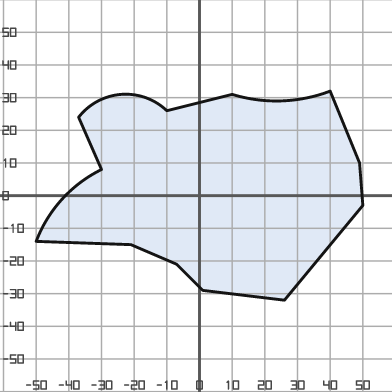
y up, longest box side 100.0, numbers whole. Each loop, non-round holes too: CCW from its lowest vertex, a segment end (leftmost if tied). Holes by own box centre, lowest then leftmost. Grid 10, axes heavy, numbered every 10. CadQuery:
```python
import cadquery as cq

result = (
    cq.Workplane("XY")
    .moveTo(26.0, -32.0)
    .lineTo(50.0, -3.0)
    .lineTo(49.0, 10.0)
    .lineTo(40.0, 32.0)
    .threePointArc((25.0, 29.0), (10.0, 31.0))
    .lineTo(-10.0, 26.0)
    .threePointArc((-24.0, 31.0), (-37.0, 24.0))
    .lineTo(-30.0, 8.0)
    .threePointArc((-42.0, -1.0), (-50.0, -14.0))
    .lineTo(-21.0, -15.0)
    .lineTo(-7.0, -21.0)
    .lineTo(1.0, -29.0)
    .close()
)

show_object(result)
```